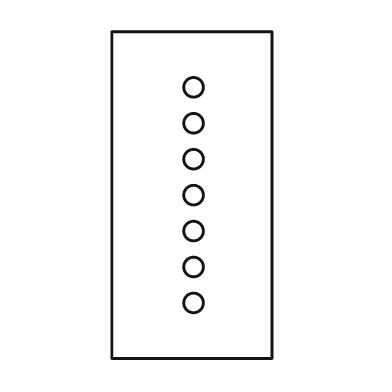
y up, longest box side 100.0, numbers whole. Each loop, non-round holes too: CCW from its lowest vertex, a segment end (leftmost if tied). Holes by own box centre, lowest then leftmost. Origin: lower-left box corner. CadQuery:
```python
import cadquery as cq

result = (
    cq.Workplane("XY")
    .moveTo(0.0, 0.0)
    .lineTo(49.0, 0.0)
    .lineTo(49.0, 100.0)
    .lineTo(0.0, 100.0)
    .close()
    .moveTo(25.0, 17.0)
    .circle(3.0)
    .moveTo(25.0, 28.0)
    .circle(3.0)
    .moveTo(25.0, 39.0)
    .circle(3.0)
    .moveTo(25.0, 50.0)
    .circle(3.0)
    .moveTo(25.0, 61.0)
    .circle(3.0)
    .moveTo(25.0, 72.0)
    .circle(3.0)
    .moveTo(25.0, 83.0)
    .circle(3.0)
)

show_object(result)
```